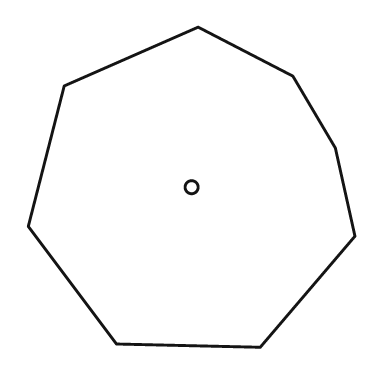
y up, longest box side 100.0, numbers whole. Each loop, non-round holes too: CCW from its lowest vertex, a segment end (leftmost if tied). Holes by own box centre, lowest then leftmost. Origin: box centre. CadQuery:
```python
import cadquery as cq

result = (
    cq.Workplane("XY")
    .moveTo(21.0, -49.0)
    .lineTo(50.0, -15.0)
    .lineTo(44.0, 12.0)
    .lineTo(31.0, 34.0)
    .lineTo(2.0, 49.0)
    .lineTo(-39.0, 31.0)
    .lineTo(-50.0, -12.0)
    .lineTo(-23.0, -48.0)
    .close()
    .moveTo(0.0, 0.0)
    .circle(2.0)
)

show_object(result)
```